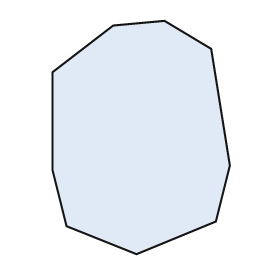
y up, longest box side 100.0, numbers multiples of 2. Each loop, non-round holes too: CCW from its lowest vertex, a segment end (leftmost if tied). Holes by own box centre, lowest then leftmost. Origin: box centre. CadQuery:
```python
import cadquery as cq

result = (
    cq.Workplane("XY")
    .moveTo(-2.0, -50.0)
    .lineTo(32.0, -36.0)
    .lineTo(38.0, -12.0)
    .lineTo(30.0, 38.0)
    .lineTo(10.0, 50.0)
    .lineTo(-12.0, 48.0)
    .lineTo(-38.0, 28.0)
    .lineTo(-38.0, -14.0)
    .lineTo(-32.0, -38.0)
    .close()
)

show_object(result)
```